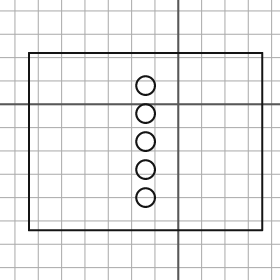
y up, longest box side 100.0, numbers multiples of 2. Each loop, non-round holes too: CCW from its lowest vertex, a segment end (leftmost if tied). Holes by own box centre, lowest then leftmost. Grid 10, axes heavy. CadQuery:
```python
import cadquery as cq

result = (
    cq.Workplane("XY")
    .moveTo(-64.0, -54.0)
    .lineTo(36.0, -54.0)
    .lineTo(36.0, 22.0)
    .lineTo(-64.0, 22.0)
    .close()
    .moveTo(-14.0, -40.0)
    .circle(4.0)
    .moveTo(-14.0, -28.0)
    .circle(4.0)
    .moveTo(-14.0, -16.0)
    .circle(4.0)
    .moveTo(-14.0, -4.0)
    .circle(4.0)
    .moveTo(-14.0, 8.0)
    .circle(4.0)
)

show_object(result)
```